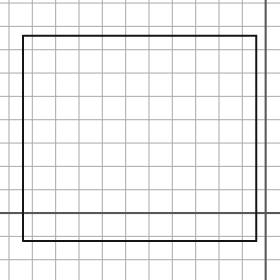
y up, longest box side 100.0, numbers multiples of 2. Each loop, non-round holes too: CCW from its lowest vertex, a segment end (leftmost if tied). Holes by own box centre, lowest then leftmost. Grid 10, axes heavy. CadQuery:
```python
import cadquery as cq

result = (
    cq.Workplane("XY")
    .moveTo(-104.0, -12.0)
    .lineTo(-4.0, -12.0)
    .lineTo(-4.0, 76.0)
    .lineTo(-104.0, 76.0)
    .close()
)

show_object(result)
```